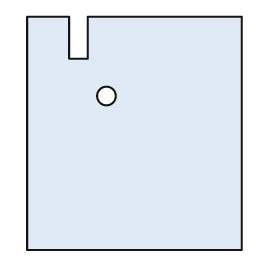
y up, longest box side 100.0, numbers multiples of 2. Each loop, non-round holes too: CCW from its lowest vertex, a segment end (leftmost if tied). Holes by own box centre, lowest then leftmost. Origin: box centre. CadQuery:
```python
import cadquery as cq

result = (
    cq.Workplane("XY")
    .moveTo(-46.0, -50.0)
    .lineTo(46.0, -50.0)
    .lineTo(46.0, 50.0)
    .lineTo(-20.0, 50.0)
    .lineTo(-20.0, 32.0)
    .lineTo(-28.0, 32.0)
    .lineTo(-28.0, 50.0)
    .lineTo(-46.0, 50.0)
    .close()
    .moveTo(-12.0, 16.0)
    .circle(4.0)
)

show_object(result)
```